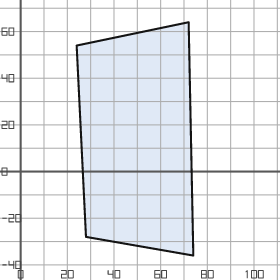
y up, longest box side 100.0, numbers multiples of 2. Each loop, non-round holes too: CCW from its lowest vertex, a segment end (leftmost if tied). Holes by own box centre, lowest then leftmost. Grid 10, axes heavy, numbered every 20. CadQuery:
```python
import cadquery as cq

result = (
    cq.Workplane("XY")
    .moveTo(74.0, -36.0)
    .lineTo(72.0, 64.0)
    .lineTo(24.0, 54.0)
    .lineTo(28.0, -28.0)
    .close()
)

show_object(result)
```